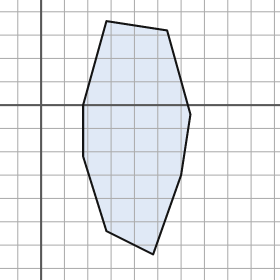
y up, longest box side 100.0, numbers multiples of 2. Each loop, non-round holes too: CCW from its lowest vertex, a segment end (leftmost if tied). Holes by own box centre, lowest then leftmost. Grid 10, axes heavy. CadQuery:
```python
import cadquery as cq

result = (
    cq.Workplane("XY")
    .moveTo(48.0, -64.0)
    .lineTo(60.0, -30.0)
    .lineTo(64.0, -4.0)
    .lineTo(54.0, 32.0)
    .lineTo(28.0, 36.0)
    .lineTo(18.0, 0.0)
    .lineTo(18.0, -22.0)
    .lineTo(28.0, -54.0)
    .close()
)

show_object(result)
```